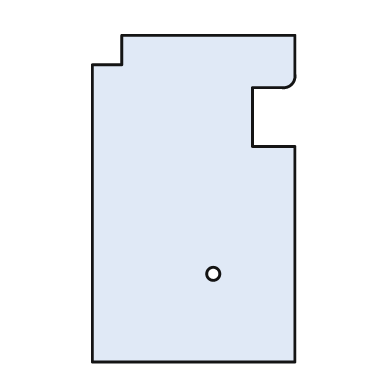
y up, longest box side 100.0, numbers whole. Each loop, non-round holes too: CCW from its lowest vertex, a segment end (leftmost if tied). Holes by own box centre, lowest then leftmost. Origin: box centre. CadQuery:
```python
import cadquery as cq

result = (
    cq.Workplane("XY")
    .moveTo(-31.0, -50.0)
    .lineTo(31.0, -50.0)
    .lineTo(31.0, 16.0)
    .lineTo(18.0, 16.0)
    .lineTo(18.0, 34.0)
    .lineTo(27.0, 34.0)
    .threePointArc((30.0, 35.0), (31.0, 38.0))
    .lineTo(31.0, 50.0)
    .lineTo(-22.0, 50.0)
    .lineTo(-22.0, 41.0)
    .lineTo(-31.0, 41.0)
    .close()
    .moveTo(6.0, -23.0)
    .circle(2.0)
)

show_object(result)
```